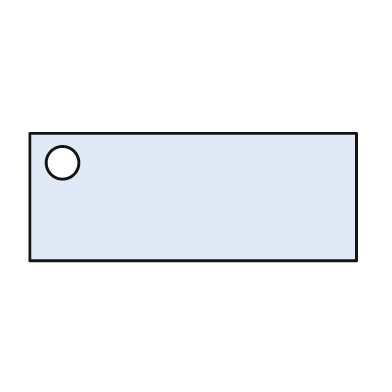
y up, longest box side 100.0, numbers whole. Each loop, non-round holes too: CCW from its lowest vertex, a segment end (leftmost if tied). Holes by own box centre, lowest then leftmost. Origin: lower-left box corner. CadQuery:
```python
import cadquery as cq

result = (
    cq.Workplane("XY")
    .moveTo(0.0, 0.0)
    .lineTo(100.0, 0.0)
    .lineTo(100.0, 39.0)
    .lineTo(0.0, 39.0)
    .close()
    .moveTo(10.0, 30.0)
    .circle(5.0)
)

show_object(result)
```